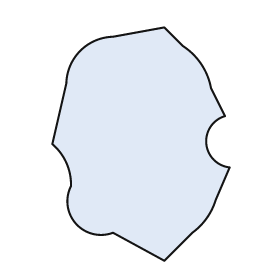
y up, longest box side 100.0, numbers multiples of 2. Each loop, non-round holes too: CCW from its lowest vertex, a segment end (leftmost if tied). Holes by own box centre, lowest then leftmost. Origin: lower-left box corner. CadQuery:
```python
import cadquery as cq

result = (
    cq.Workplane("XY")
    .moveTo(48.0, 0.0)
    .lineTo(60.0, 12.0)
    .threePointArc((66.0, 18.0), (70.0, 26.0))
    .lineTo(76.0, 40.0)
    .threePointArc((66.0, 50.0), (74.0, 62.0))
    .lineTo(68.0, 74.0)
    .threePointArc((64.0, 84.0), (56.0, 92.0))
    .lineTo(48.0, 100.0)
    .lineTo(26.0, 96.0)
    .threePointArc((12.0, 90.0), (6.0, 76.0))
    .lineTo(0.0, 50.0)
    .threePointArc((6.0, 42.0), (8.0, 32.0))
    .threePointArc((10.0, 16.0), (26.0, 12.0))
    .close()
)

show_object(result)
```